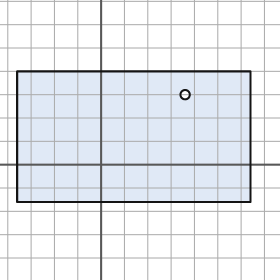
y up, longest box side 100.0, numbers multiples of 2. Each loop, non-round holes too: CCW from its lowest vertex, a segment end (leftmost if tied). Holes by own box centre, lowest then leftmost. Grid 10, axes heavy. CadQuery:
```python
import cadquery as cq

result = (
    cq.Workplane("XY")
    .moveTo(-36.0, -16.0)
    .lineTo(64.0, -16.0)
    .lineTo(64.0, 40.0)
    .lineTo(-36.0, 40.0)
    .close()
    .moveTo(36.0, 30.0)
    .circle(2.0)
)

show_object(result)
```